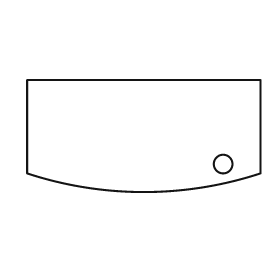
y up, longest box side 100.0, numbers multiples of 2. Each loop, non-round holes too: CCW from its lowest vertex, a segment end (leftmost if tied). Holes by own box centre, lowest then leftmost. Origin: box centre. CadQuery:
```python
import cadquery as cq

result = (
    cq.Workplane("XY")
    .moveTo(-50.0, -16.0)
    .threePointArc((0.0, -24.0), (50.0, -16.0))
    .lineTo(50.0, 24.0)
    .lineTo(-50.0, 24.0)
    .close()
    .moveTo(34.0, -12.0)
    .circle(4.0)
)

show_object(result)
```